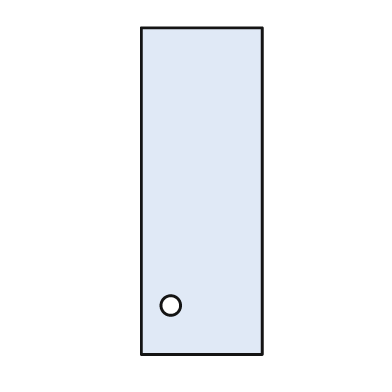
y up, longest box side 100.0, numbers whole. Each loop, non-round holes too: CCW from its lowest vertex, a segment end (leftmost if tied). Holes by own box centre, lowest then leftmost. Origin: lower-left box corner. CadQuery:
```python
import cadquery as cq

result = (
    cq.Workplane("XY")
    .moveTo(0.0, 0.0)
    .lineTo(37.0, 0.0)
    .lineTo(37.0, 100.0)
    .lineTo(0.0, 100.0)
    .close()
    .moveTo(9.0, 15.0)
    .circle(3.0)
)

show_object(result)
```